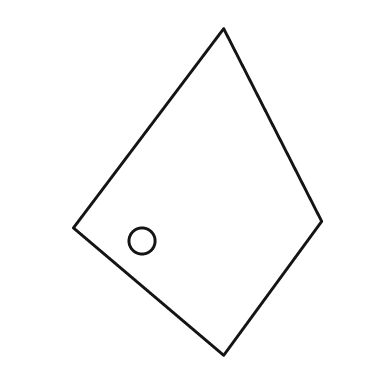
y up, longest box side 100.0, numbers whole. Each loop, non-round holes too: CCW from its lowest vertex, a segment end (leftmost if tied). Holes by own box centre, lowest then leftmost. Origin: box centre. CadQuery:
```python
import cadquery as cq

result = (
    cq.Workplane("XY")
    .moveTo(8.0, -50.0)
    .lineTo(38.0, -9.0)
    .lineTo(8.0, 50.0)
    .lineTo(-38.0, -11.0)
    .close()
    .moveTo(-17.0, -15.0)
    .circle(4.0)
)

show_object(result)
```